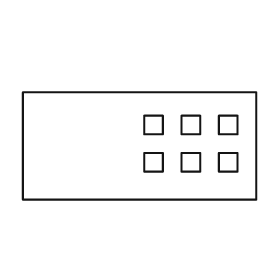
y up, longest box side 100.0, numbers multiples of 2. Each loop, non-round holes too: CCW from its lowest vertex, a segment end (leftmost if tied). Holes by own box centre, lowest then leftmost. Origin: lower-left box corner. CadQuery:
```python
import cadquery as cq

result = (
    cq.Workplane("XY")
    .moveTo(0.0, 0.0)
    .lineTo(100.0, 0.0)
    .lineTo(100.0, 46.0)
    .lineTo(0.0, 46.0)
    .close()
    .moveTo(52.0, 12.0)
    .lineTo(60.0, 12.0)
    .lineTo(60.0, 20.0)
    .lineTo(52.0, 20.0)
    .close()
    .moveTo(68.0, 12.0)
    .lineTo(76.0, 12.0)
    .lineTo(76.0, 20.0)
    .lineTo(68.0, 20.0)
    .close()
    .moveTo(84.0, 12.0)
    .lineTo(92.0, 12.0)
    .lineTo(92.0, 20.0)
    .lineTo(84.0, 20.0)
    .close()
    .moveTo(52.0, 28.0)
    .lineTo(60.0, 28.0)
    .lineTo(60.0, 36.0)
    .lineTo(52.0, 36.0)
    .close()
    .moveTo(68.0, 28.0)
    .lineTo(76.0, 28.0)
    .lineTo(76.0, 36.0)
    .lineTo(68.0, 36.0)
    .close()
    .moveTo(84.0, 28.0)
    .lineTo(92.0, 28.0)
    .lineTo(92.0, 36.0)
    .lineTo(84.0, 36.0)
    .close()
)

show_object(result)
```